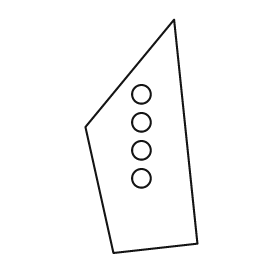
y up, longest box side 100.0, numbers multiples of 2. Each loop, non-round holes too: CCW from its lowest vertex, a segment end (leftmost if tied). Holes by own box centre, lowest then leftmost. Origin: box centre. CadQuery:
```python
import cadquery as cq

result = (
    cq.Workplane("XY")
    .moveTo(-12.0, -50.0)
    .lineTo(24.0, -46.0)
    .lineTo(14.0, 50.0)
    .lineTo(-24.0, 4.0)
    .close()
    .moveTo(0.0, -18.0)
    .circle(4.0)
    .moveTo(0.0, -6.0)
    .circle(4.0)
    .moveTo(0.0, 6.0)
    .circle(4.0)
    .moveTo(0.0, 18.0)
    .circle(4.0)
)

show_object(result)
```